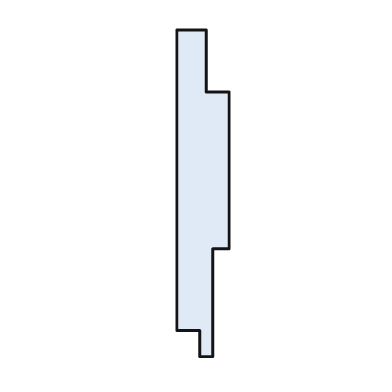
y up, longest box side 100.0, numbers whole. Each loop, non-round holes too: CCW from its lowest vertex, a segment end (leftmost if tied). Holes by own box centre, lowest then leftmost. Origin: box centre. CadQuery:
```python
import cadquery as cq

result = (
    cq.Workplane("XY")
    .moveTo(-1.0, -50.0)
    .lineTo(3.0, -50.0)
    .lineTo(3.0, -17.0)
    .lineTo(8.0, -17.0)
    .lineTo(8.0, 31.0)
    .lineTo(1.0, 31.0)
    .lineTo(1.0, 50.0)
    .lineTo(-8.0, 50.0)
    .lineTo(-8.0, -42.0)
    .lineTo(-1.0, -42.0)
    .close()
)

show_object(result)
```